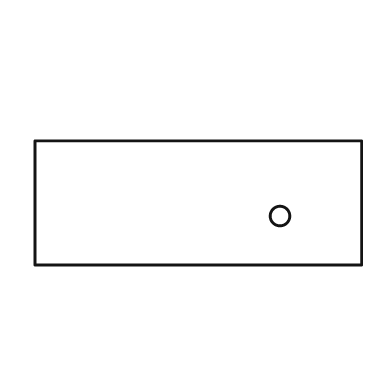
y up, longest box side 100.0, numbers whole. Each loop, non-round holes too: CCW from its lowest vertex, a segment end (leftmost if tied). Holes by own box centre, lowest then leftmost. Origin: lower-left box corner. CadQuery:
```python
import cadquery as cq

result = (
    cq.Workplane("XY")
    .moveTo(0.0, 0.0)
    .lineTo(100.0, 0.0)
    .lineTo(100.0, 38.0)
    .lineTo(0.0, 38.0)
    .close()
    .moveTo(75.0, 15.0)
    .circle(3.0)
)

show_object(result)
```